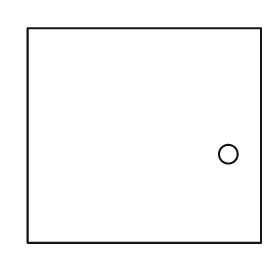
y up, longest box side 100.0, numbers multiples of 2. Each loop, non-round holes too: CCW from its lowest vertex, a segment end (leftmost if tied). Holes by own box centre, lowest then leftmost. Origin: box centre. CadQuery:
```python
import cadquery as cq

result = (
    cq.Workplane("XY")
    .moveTo(-50.0, -46.0)
    .lineTo(50.0, -46.0)
    .lineTo(50.0, 46.0)
    .lineTo(-50.0, 46.0)
    .close()
    .moveTo(36.0, -8.0)
    .circle(4.0)
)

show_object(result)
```